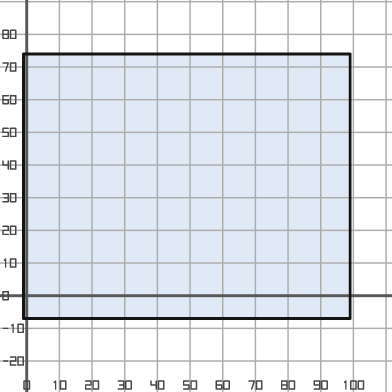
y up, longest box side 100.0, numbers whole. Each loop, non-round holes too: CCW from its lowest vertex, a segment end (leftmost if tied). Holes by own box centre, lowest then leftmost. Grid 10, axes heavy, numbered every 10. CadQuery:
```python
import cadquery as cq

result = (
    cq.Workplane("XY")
    .moveTo(-1.0, -7.0)
    .lineTo(99.0, -7.0)
    .lineTo(99.0, 74.0)
    .lineTo(-1.0, 74.0)
    .close()
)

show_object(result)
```